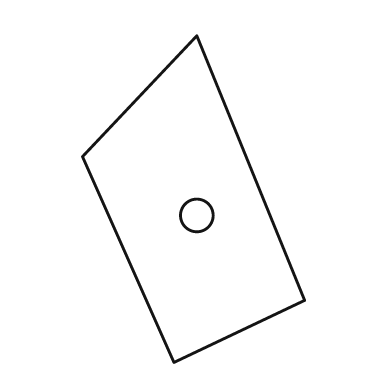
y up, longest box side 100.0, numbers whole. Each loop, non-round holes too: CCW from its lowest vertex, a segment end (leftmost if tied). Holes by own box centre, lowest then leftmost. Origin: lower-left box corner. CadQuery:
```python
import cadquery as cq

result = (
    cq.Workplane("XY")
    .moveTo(28.0, 0.0)
    .lineTo(68.0, 19.0)
    .lineTo(35.0, 100.0)
    .lineTo(0.0, 63.0)
    .close()
    .moveTo(35.0, 45.0)
    .circle(5.0)
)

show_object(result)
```